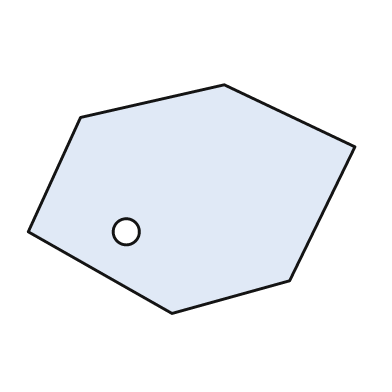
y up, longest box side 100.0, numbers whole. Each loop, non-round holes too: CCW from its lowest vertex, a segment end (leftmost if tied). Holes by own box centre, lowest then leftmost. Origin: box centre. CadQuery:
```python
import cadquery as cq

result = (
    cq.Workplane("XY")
    .moveTo(-6.0, -35.0)
    .lineTo(30.0, -25.0)
    .lineTo(50.0, 16.0)
    .lineTo(10.0, 35.0)
    .lineTo(-34.0, 25.0)
    .lineTo(-50.0, -10.0)
    .close()
    .moveTo(-20.0, -10.0)
    .circle(4.0)
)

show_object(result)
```